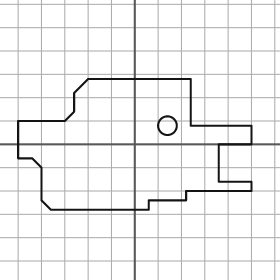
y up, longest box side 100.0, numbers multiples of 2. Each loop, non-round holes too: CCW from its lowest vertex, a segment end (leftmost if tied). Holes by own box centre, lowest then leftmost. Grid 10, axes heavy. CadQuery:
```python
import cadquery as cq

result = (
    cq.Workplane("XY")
    .moveTo(-36.0, -28.0)
    .lineTo(6.0, -28.0)
    .lineTo(6.0, -24.0)
    .lineTo(22.0, -24.0)
    .lineTo(22.0, -20.0)
    .lineTo(50.0, -20.0)
    .lineTo(50.0, -16.0)
    .lineTo(36.0, -16.0)
    .lineTo(36.0, 0.0)
    .lineTo(50.0, 0.0)
    .lineTo(50.0, 8.0)
    .lineTo(24.0, 8.0)
    .lineTo(24.0, 28.0)
    .lineTo(-20.0, 28.0)
    .lineTo(-26.0, 22.0)
    .lineTo(-26.0, 14.0)
    .lineTo(-30.0, 10.0)
    .lineTo(-50.0, 10.0)
    .lineTo(-50.0, -6.0)
    .lineTo(-44.0, -6.0)
    .lineTo(-40.0, -10.0)
    .lineTo(-40.0, -24.0)
    .close()
    .moveTo(14.0, 8.0)
    .circle(4.0)
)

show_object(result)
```